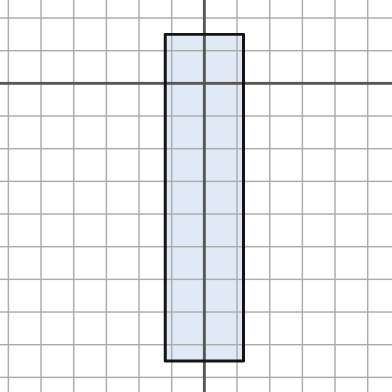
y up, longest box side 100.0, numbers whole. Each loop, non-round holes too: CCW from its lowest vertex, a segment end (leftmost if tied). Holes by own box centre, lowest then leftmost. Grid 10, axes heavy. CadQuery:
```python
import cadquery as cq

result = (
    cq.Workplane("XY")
    .moveTo(-12.0, -85.0)
    .lineTo(12.0, -85.0)
    .lineTo(12.0, 15.0)
    .lineTo(-12.0, 15.0)
    .close()
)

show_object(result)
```